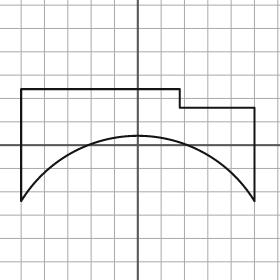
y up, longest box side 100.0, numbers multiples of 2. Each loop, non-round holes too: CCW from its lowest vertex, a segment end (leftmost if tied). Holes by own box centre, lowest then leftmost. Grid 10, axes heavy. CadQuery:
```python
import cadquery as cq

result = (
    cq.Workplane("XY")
    .moveTo(-50.0, -24.0)
    .threePointArc((0.0, 4.0), (50.0, -24.0))
    .lineTo(50.0, 16.0)
    .lineTo(18.0, 16.0)
    .lineTo(18.0, 24.0)
    .lineTo(-50.0, 24.0)
    .close()
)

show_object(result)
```